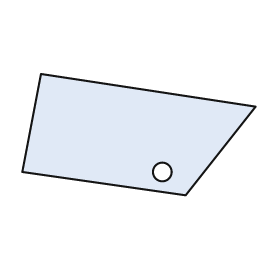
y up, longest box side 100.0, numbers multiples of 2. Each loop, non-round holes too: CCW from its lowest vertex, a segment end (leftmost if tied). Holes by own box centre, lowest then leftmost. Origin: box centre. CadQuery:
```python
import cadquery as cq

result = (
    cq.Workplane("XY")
    .moveTo(20.0, -26.0)
    .lineTo(50.0, 12.0)
    .lineTo(-42.0, 26.0)
    .lineTo(-50.0, -16.0)
    .close()
    .moveTo(10.0, -16.0)
    .circle(4.0)
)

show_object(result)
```